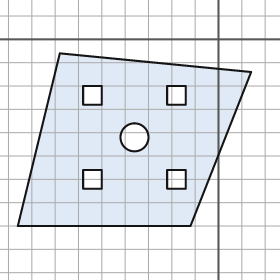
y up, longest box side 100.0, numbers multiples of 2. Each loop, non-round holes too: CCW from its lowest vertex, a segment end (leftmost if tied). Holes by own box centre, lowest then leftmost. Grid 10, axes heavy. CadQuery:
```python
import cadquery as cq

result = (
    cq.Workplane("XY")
    .moveTo(-86.0, -80.0)
    .lineTo(-12.0, -80.0)
    .lineTo(14.0, -14.0)
    .lineTo(-68.0, -6.0)
    .close()
    .moveTo(-58.0, -64.0)
    .lineTo(-50.0, -64.0)
    .lineTo(-50.0, -56.0)
    .lineTo(-58.0, -56.0)
    .close()
    .moveTo(-22.0, -64.0)
    .lineTo(-14.0, -64.0)
    .lineTo(-14.0, -56.0)
    .lineTo(-22.0, -56.0)
    .close()
    .moveTo(-36.0, -42.0)
    .circle(6.0)
    .moveTo(-58.0, -28.0)
    .lineTo(-50.0, -28.0)
    .lineTo(-50.0, -20.0)
    .lineTo(-58.0, -20.0)
    .close()
    .moveTo(-22.0, -28.0)
    .lineTo(-14.0, -28.0)
    .lineTo(-14.0, -20.0)
    .lineTo(-22.0, -20.0)
    .close()
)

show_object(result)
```